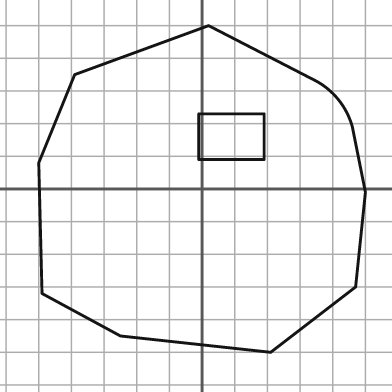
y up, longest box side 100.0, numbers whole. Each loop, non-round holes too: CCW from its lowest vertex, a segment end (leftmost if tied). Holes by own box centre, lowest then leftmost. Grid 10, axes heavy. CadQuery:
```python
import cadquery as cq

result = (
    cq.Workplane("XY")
    .moveTo(21.0, -50.0)
    .lineTo(47.0, -30.0)
    .lineTo(50.0, -1.0)
    .lineTo(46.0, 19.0)
    .threePointArc((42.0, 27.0), (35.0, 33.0))
    .lineTo(2.0, 50.0)
    .lineTo(-39.0, 35.0)
    .lineTo(-50.0, 8.0)
    .lineTo(-49.0, -32.0)
    .lineTo(-25.0, -45.0)
    .close()
    .moveTo(-1.0, 9.0)
    .lineTo(19.0, 9.0)
    .lineTo(19.0, 23.0)
    .lineTo(-1.0, 23.0)
    .close()
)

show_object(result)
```